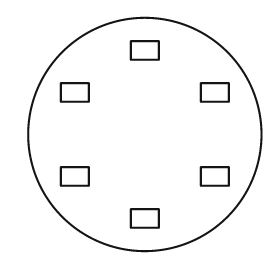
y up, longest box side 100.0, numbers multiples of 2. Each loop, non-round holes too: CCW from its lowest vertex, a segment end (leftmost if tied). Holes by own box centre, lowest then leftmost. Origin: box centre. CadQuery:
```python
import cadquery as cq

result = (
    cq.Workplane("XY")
    .moveTo(0.0, 0.0)
    .circle(50.0)
    .moveTo(-6.0, -40.0)
    .lineTo(6.0, -40.0)
    .lineTo(6.0, -32.0)
    .lineTo(-6.0, -32.0)
    .close()
    .moveTo(-36.0, -22.0)
    .lineTo(-24.0, -22.0)
    .lineTo(-24.0, -14.0)
    .lineTo(-36.0, -14.0)
    .close()
    .moveTo(24.0, -22.0)
    .lineTo(36.0, -22.0)
    .lineTo(36.0, -14.0)
    .lineTo(24.0, -14.0)
    .close()
    .moveTo(-36.0, 14.0)
    .lineTo(-24.0, 14.0)
    .lineTo(-24.0, 22.0)
    .lineTo(-36.0, 22.0)
    .close()
    .moveTo(24.0, 14.0)
    .lineTo(36.0, 14.0)
    .lineTo(36.0, 22.0)
    .lineTo(24.0, 22.0)
    .close()
    .moveTo(-6.0, 32.0)
    .lineTo(6.0, 32.0)
    .lineTo(6.0, 40.0)
    .lineTo(-6.0, 40.0)
    .close()
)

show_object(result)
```